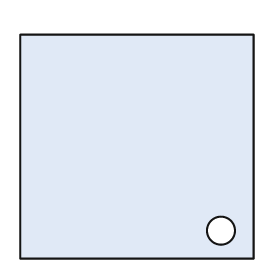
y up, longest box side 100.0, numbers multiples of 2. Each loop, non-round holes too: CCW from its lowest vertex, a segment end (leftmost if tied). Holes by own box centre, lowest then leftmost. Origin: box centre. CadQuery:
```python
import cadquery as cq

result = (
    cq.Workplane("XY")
    .moveTo(-50.0, -48.0)
    .lineTo(50.0, -48.0)
    .lineTo(50.0, 48.0)
    .lineTo(-50.0, 48.0)
    .close()
    .moveTo(36.0, -36.0)
    .circle(6.0)
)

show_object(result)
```